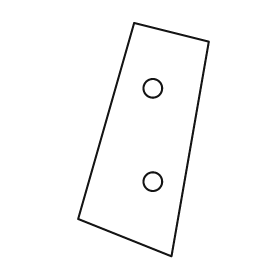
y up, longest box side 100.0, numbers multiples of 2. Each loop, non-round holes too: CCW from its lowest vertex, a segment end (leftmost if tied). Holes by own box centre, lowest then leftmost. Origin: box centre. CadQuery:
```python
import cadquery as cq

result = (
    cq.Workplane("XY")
    .moveTo(12.0, -50.0)
    .lineTo(28.0, 42.0)
    .lineTo(-4.0, 50.0)
    .lineTo(-28.0, -34.0)
    .close()
    .moveTo(4.0, -18.0)
    .circle(4.0)
    .moveTo(4.0, 22.0)
    .circle(4.0)
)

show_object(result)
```